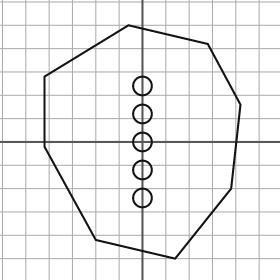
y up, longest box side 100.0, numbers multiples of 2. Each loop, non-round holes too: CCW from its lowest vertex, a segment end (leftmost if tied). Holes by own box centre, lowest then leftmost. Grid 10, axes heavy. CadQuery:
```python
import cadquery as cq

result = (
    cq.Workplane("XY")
    .moveTo(14.0, -50.0)
    .lineTo(38.0, -20.0)
    .lineTo(42.0, 16.0)
    .lineTo(28.0, 42.0)
    .lineTo(-6.0, 50.0)
    .lineTo(-42.0, 28.0)
    .lineTo(-42.0, -2.0)
    .lineTo(-20.0, -42.0)
    .close()
    .moveTo(0.0, -24.0)
    .circle(4.0)
    .moveTo(0.0, -12.0)
    .circle(4.0)
    .moveTo(0.0, 0.0)
    .circle(4.0)
    .moveTo(0.0, 12.0)
    .circle(4.0)
    .moveTo(0.0, 24.0)
    .circle(4.0)
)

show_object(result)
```